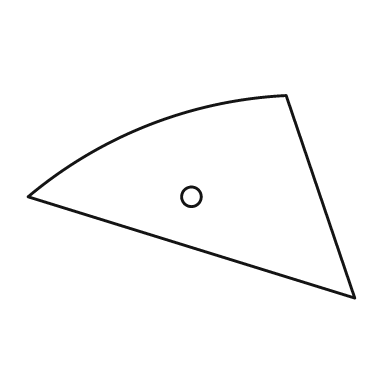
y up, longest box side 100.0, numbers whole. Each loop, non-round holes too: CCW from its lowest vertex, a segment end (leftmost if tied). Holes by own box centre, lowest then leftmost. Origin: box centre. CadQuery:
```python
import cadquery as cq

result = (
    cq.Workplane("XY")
    .moveTo(50.0, -31.0)
    .lineTo(29.0, 31.0)
    .threePointArc((-13.0, 22.0), (-50.0, 0.0))
    .close()
    .moveTo(0.0, 0.0)
    .circle(3.0)
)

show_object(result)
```